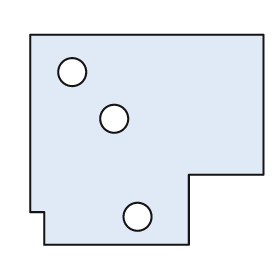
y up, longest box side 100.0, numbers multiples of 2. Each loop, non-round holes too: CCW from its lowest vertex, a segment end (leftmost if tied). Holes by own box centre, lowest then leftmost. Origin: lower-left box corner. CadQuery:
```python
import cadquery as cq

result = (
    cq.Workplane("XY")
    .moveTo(6.0, 0.0)
    .lineTo(68.0, 0.0)
    .lineTo(68.0, 30.0)
    .lineTo(100.0, 30.0)
    .lineTo(100.0, 90.0)
    .lineTo(0.0, 90.0)
    .lineTo(0.0, 14.0)
    .lineTo(6.0, 14.0)
    .close()
    .moveTo(46.0, 12.0)
    .circle(6.0)
    .moveTo(36.0, 54.0)
    .circle(6.0)
    .moveTo(18.0, 74.0)
    .circle(6.0)
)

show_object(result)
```